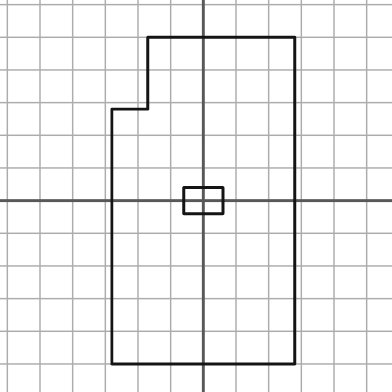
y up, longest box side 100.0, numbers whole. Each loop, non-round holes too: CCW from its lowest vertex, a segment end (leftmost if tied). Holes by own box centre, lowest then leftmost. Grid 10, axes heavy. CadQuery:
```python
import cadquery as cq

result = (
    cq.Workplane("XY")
    .moveTo(-28.0, -50.0)
    .lineTo(28.0, -50.0)
    .lineTo(28.0, 50.0)
    .lineTo(-17.0, 50.0)
    .lineTo(-17.0, 28.0)
    .lineTo(-28.0, 28.0)
    .close()
    .moveTo(-6.0, -4.0)
    .lineTo(6.0, -4.0)
    .lineTo(6.0, 4.0)
    .lineTo(-6.0, 4.0)
    .close()
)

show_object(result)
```